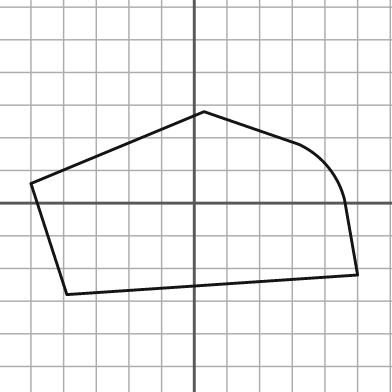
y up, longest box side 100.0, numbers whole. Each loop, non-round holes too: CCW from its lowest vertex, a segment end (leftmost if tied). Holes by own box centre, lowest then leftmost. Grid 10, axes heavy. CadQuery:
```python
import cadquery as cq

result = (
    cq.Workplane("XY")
    .moveTo(-39.0, -28.0)
    .lineTo(50.0, -22.0)
    .lineTo(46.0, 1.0)
    .threePointArc((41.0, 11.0), (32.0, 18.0))
    .lineTo(3.0, 28.0)
    .lineTo(-50.0, 6.0)
    .close()
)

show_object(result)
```